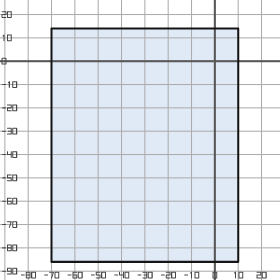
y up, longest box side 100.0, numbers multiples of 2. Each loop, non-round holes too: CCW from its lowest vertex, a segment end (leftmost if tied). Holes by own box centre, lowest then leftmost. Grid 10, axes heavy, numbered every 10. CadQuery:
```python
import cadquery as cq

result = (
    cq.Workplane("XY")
    .moveTo(-70.0, -86.0)
    .lineTo(10.0, -86.0)
    .lineTo(10.0, 14.0)
    .lineTo(-70.0, 14.0)
    .close()
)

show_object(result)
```